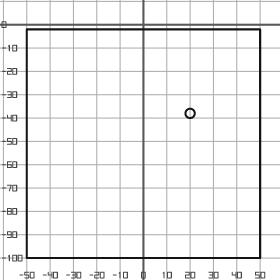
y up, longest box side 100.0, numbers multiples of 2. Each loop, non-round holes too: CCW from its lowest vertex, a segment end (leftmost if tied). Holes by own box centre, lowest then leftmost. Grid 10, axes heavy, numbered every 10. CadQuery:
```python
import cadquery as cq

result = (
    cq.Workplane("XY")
    .moveTo(-50.0, -100.0)
    .lineTo(50.0, -100.0)
    .lineTo(50.0, -2.0)
    .lineTo(-50.0, -2.0)
    .close()
    .moveTo(20.0, -38.0)
    .circle(2.0)
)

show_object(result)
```